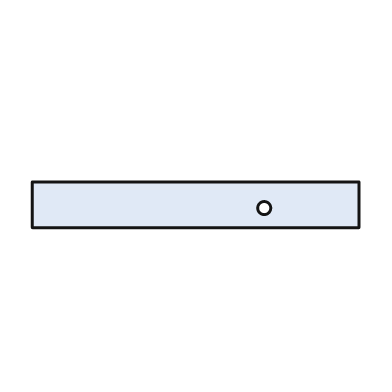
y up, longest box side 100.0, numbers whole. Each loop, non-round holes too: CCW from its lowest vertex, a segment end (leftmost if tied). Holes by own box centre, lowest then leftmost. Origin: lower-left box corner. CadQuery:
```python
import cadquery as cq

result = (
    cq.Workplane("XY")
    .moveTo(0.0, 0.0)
    .lineTo(100.0, 0.0)
    .lineTo(100.0, 14.0)
    .lineTo(0.0, 14.0)
    .close()
    .moveTo(71.0, 6.0)
    .circle(2.0)
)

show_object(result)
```